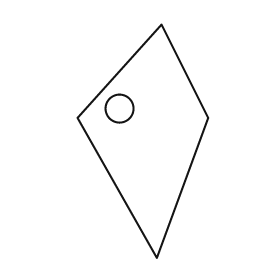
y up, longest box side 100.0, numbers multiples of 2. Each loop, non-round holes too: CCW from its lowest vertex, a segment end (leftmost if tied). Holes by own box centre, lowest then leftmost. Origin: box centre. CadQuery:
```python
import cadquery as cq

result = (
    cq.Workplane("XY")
    .moveTo(6.0, -50.0)
    .lineTo(28.0, 10.0)
    .lineTo(8.0, 50.0)
    .lineTo(-28.0, 10.0)
    .close()
    .moveTo(-10.0, 14.0)
    .circle(6.0)
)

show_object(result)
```